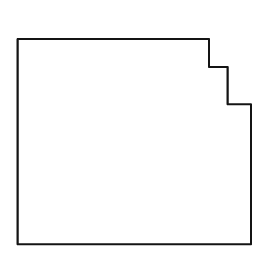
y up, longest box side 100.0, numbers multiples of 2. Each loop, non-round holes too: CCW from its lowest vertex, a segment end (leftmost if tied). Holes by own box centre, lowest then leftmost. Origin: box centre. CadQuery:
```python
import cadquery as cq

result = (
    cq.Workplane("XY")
    .moveTo(-50.0, -44.0)
    .lineTo(50.0, -44.0)
    .lineTo(50.0, 16.0)
    .lineTo(40.0, 16.0)
    .lineTo(40.0, 32.0)
    .lineTo(32.0, 32.0)
    .lineTo(32.0, 44.0)
    .lineTo(-50.0, 44.0)
    .close()
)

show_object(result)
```